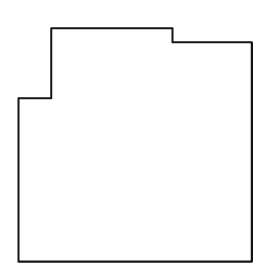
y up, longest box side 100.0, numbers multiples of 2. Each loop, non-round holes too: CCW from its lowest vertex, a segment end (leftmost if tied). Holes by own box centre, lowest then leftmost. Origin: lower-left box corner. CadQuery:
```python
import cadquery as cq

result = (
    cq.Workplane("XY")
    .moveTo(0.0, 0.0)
    .lineTo(100.0, 0.0)
    .lineTo(100.0, 94.0)
    .lineTo(66.0, 94.0)
    .lineTo(66.0, 100.0)
    .lineTo(14.0, 100.0)
    .lineTo(14.0, 70.0)
    .lineTo(0.0, 70.0)
    .close()
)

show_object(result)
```